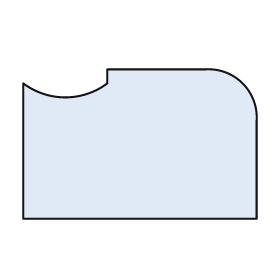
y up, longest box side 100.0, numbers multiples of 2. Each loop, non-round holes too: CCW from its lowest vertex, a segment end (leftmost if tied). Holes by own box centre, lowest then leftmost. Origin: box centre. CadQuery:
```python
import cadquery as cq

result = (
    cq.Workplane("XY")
    .moveTo(-50.0, -32.0)
    .lineTo(50.0, -32.0)
    .lineTo(50.0, 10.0)
    .threePointArc((44.0, 26.0), (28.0, 32.0))
    .lineTo(-14.0, 32.0)
    .lineTo(-14.0, 26.0)
    .threePointArc((-32.0, 20.0), (-50.0, 26.0))
    .close()
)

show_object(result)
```